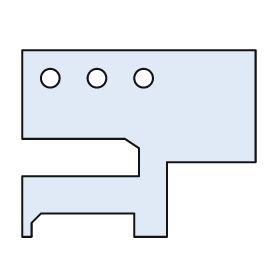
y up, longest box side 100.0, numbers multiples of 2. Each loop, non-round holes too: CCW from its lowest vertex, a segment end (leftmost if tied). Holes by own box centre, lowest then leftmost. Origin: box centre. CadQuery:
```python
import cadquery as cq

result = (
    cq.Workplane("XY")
    .moveTo(-50.0, -40.0)
    .lineTo(-46.0, -40.0)
    .lineTo(-46.0, -34.0)
    .lineTo(-42.0, -30.0)
    .lineTo(-2.0, -30.0)
    .lineTo(-2.0, -40.0)
    .lineTo(12.0, -40.0)
    .lineTo(12.0, -8.0)
    .lineTo(50.0, -8.0)
    .lineTo(50.0, 40.0)
    .lineTo(-50.0, 40.0)
    .lineTo(-50.0, 2.0)
    .lineTo(-6.0, 2.0)
    .lineTo(0.0, -2.0)
    .lineTo(0.0, -14.0)
    .lineTo(-50.0, -14.0)
    .close()
    .moveTo(-38.0, 28.0)
    .circle(4.0)
    .moveTo(-18.0, 28.0)
    .circle(4.0)
    .moveTo(2.0, 28.0)
    .circle(4.0)
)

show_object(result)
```